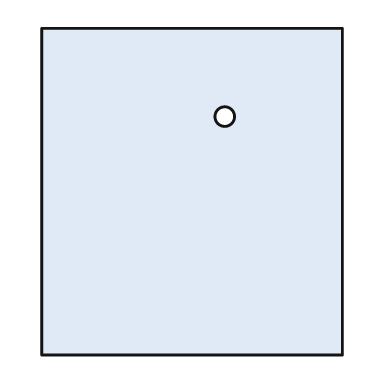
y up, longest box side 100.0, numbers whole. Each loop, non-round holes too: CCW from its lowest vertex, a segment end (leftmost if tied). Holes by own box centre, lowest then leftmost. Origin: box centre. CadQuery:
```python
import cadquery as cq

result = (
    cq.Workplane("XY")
    .moveTo(-46.0, -50.0)
    .lineTo(46.0, -50.0)
    .lineTo(46.0, 50.0)
    .lineTo(-46.0, 50.0)
    .close()
    .moveTo(10.0, 23.0)
    .circle(3.0)
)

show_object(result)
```